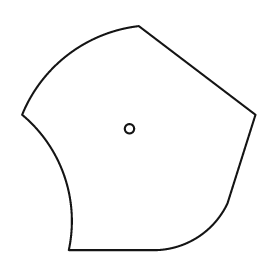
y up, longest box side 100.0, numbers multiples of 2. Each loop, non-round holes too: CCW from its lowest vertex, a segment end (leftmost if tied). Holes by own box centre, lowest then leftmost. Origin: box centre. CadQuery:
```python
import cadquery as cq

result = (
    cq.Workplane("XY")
    .moveTo(-30.0, -48.0)
    .lineTo(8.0, -48.0)
    .threePointArc((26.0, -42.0), (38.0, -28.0))
    .lineTo(50.0, 10.0)
    .lineTo(0.0, 48.0)
    .threePointArc((-30.0, 36.0), (-50.0, 10.0))
    .threePointArc((-32.0, -16.0), (-30.0, -48.0))
    .close()
    .moveTo(-4.0, 4.0)
    .circle(2.0)
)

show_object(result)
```